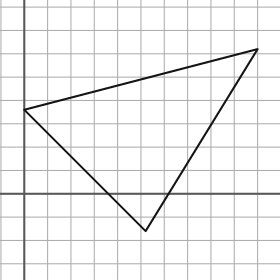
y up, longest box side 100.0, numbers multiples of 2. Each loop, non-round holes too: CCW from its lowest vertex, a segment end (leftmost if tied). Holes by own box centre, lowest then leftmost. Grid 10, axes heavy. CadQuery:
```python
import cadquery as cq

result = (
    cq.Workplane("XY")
    .moveTo(52.0, -16.0)
    .lineTo(100.0, 62.0)
    .lineTo(0.0, 36.0)
    .close()
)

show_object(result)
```